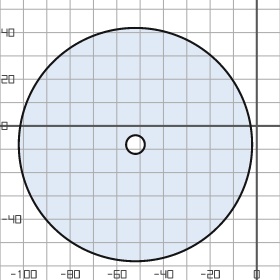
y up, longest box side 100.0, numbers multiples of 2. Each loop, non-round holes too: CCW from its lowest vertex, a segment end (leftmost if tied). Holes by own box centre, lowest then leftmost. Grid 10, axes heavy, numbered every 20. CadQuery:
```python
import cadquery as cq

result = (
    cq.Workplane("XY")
    .moveTo(-52.0, -8.0)
    .circle(50.0)
    .moveTo(-52.0, -8.0)
    .circle(4.0)
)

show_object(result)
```